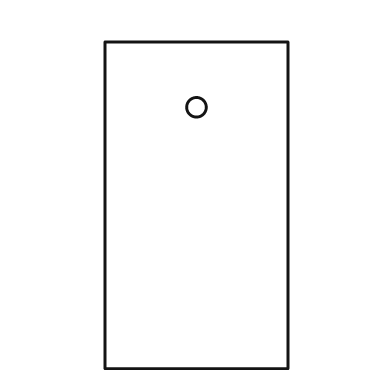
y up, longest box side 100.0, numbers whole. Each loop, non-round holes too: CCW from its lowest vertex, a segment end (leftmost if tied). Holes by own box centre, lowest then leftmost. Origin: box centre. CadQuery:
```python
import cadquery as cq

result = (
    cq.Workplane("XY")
    .moveTo(-28.0, -50.0)
    .lineTo(28.0, -50.0)
    .lineTo(28.0, 50.0)
    .lineTo(-28.0, 50.0)
    .close()
    .moveTo(0.0, 30.0)
    .circle(3.0)
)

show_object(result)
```